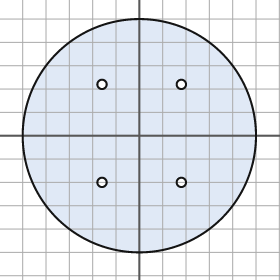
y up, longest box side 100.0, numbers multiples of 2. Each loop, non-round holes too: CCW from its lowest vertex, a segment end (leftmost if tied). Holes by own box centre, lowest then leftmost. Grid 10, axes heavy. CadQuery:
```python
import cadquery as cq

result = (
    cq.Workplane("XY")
    .moveTo(0.0, 0.0)
    .circle(50.0)
    .moveTo(-16.0, -20.0)
    .circle(2.0)
    .moveTo(18.0, -20.0)
    .circle(2.0)
    .moveTo(-16.0, 22.0)
    .circle(2.0)
    .moveTo(18.0, 22.0)
    .circle(2.0)
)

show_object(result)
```